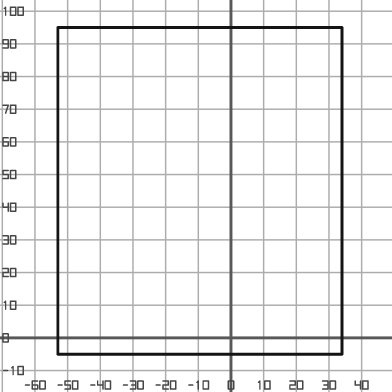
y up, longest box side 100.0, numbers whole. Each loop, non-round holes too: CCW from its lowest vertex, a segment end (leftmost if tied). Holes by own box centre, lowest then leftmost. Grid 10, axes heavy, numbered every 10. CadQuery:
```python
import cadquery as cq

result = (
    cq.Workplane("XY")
    .moveTo(-53.0, -5.0)
    .lineTo(34.0, -5.0)
    .lineTo(34.0, 95.0)
    .lineTo(-53.0, 95.0)
    .close()
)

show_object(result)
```